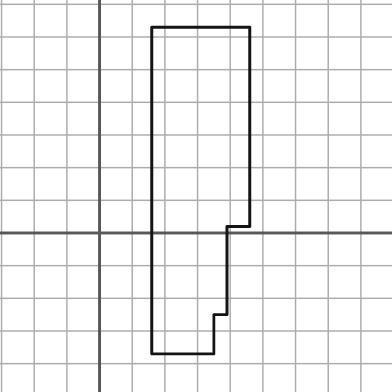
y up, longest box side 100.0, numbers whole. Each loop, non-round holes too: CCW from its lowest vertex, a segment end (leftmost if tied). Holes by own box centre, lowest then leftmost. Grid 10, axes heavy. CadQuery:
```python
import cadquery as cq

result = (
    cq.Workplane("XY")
    .moveTo(16.0, -37.0)
    .lineTo(35.0, -37.0)
    .lineTo(35.0, -25.0)
    .lineTo(39.0, -25.0)
    .lineTo(39.0, 2.0)
    .lineTo(46.0, 2.0)
    .lineTo(46.0, 63.0)
    .lineTo(16.0, 63.0)
    .close()
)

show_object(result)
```